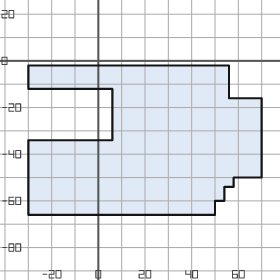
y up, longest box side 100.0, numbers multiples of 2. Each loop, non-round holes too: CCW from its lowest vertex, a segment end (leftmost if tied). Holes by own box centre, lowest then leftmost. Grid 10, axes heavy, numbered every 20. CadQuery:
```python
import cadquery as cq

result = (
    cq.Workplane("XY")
    .moveTo(-30.0, -66.0)
    .lineTo(50.0, -66.0)
    .lineTo(50.0, -60.0)
    .lineTo(54.0, -60.0)
    .lineTo(54.0, -54.0)
    .lineTo(58.0, -54.0)
    .lineTo(58.0, -50.0)
    .lineTo(70.0, -50.0)
    .lineTo(70.0, -16.0)
    .lineTo(56.0, -16.0)
    .lineTo(56.0, -2.0)
    .lineTo(-30.0, -2.0)
    .lineTo(-30.0, -12.0)
    .lineTo(6.0, -12.0)
    .lineTo(6.0, -34.0)
    .lineTo(-30.0, -34.0)
    .close()
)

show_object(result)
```